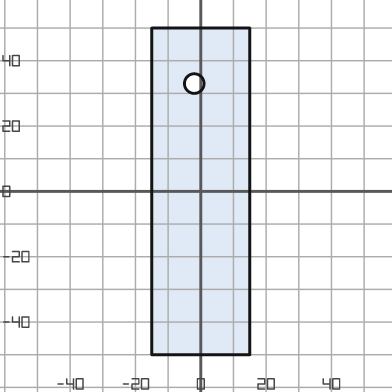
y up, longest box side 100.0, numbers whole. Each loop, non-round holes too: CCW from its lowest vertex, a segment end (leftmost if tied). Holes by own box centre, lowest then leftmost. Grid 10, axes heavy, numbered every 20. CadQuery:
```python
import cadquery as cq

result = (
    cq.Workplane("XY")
    .moveTo(-15.0, -50.0)
    .lineTo(15.0, -50.0)
    .lineTo(15.0, 50.0)
    .lineTo(-15.0, 50.0)
    .close()
    .moveTo(-2.0, 33.0)
    .circle(3.0)
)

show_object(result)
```